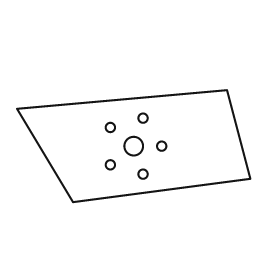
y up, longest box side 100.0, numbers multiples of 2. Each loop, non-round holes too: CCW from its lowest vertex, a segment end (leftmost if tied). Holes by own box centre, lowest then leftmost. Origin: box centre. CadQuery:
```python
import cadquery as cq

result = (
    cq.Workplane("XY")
    .moveTo(-26.0, -24.0)
    .lineTo(50.0, -14.0)
    .lineTo(40.0, 24.0)
    .lineTo(-50.0, 16.0)
    .close()
    .moveTo(4.0, -12.0)
    .circle(2.0)
    .moveTo(-10.0, -8.0)
    .circle(2.0)
    .moveTo(0.0, 0.0)
    .circle(4.0)
    .moveTo(12.0, 0.0)
    .circle(2.0)
    .moveTo(-10.0, 8.0)
    .circle(2.0)
    .moveTo(4.0, 12.0)
    .circle(2.0)
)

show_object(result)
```